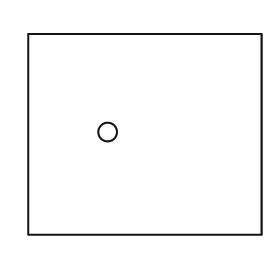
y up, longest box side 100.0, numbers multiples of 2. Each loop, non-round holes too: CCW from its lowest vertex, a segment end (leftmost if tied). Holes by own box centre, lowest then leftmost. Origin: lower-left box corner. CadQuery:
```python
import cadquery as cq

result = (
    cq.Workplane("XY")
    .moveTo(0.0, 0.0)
    .lineTo(100.0, 0.0)
    .lineTo(100.0, 86.0)
    .lineTo(0.0, 86.0)
    .close()
    .moveTo(34.0, 44.0)
    .circle(4.0)
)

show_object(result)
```